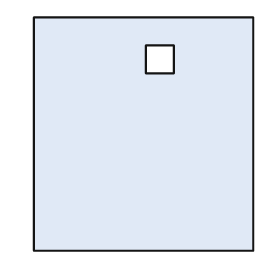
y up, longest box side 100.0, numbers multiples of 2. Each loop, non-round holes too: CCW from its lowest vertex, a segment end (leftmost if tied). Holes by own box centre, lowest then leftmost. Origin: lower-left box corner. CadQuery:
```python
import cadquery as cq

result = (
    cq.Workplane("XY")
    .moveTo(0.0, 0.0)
    .lineTo(94.0, 0.0)
    .lineTo(94.0, 100.0)
    .lineTo(0.0, 100.0)
    .close()
    .moveTo(48.0, 76.0)
    .lineTo(60.0, 76.0)
    .lineTo(60.0, 88.0)
    .lineTo(48.0, 88.0)
    .close()
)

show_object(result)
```